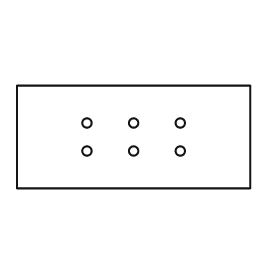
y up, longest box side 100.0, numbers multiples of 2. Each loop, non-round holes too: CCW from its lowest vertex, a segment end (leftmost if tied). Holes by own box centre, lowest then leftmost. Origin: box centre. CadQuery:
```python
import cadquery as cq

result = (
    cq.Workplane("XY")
    .moveTo(-50.0, -22.0)
    .lineTo(50.0, -22.0)
    .lineTo(50.0, 22.0)
    .lineTo(-50.0, 22.0)
    .close()
    .moveTo(-20.0, -6.0)
    .circle(2.0)
    .moveTo(0.0, -6.0)
    .circle(2.0)
    .moveTo(20.0, -6.0)
    .circle(2.0)
    .moveTo(-20.0, 6.0)
    .circle(2.0)
    .moveTo(0.0, 6.0)
    .circle(2.0)
    .moveTo(20.0, 6.0)
    .circle(2.0)
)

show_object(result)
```